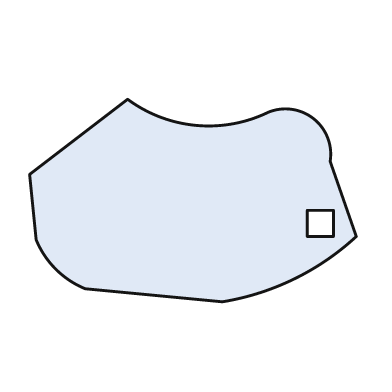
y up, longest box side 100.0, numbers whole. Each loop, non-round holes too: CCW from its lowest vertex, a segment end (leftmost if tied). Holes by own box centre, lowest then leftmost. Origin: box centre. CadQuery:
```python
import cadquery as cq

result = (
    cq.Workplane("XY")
    .moveTo(9.0, -31.0)
    .threePointArc((31.0, -24.0), (50.0, -11.0))
    .lineTo(42.0, 12.0)
    .threePointArc((37.0, 25.0), (23.0, 27.0))
    .threePointArc((1.0, 23.0), (-20.0, 31.0))
    .lineTo(-50.0, 8.0)
    .lineTo(-48.0, -12.0)
    .threePointArc((-42.0, -21.0), (-33.0, -27.0))
    .close()
    .moveTo(35.0, -11.0)
    .lineTo(43.0, -11.0)
    .lineTo(43.0, -3.0)
    .lineTo(35.0, -3.0)
    .close()
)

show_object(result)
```